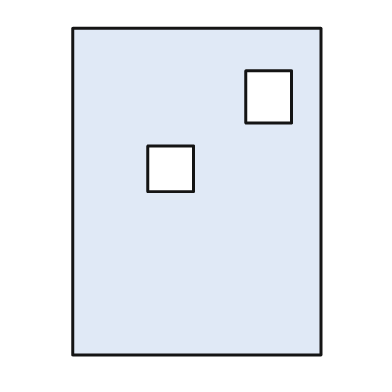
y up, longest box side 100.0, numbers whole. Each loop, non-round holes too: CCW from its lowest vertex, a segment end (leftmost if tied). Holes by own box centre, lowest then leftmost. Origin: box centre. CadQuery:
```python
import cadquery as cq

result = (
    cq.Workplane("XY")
    .moveTo(-38.0, -50.0)
    .lineTo(38.0, -50.0)
    .lineTo(38.0, 50.0)
    .lineTo(-38.0, 50.0)
    .close()
    .moveTo(-15.0, 0.0)
    .lineTo(-1.0, 0.0)
    .lineTo(-1.0, 14.0)
    .lineTo(-15.0, 14.0)
    .close()
    .moveTo(15.0, 21.0)
    .lineTo(29.0, 21.0)
    .lineTo(29.0, 37.0)
    .lineTo(15.0, 37.0)
    .close()
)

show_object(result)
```